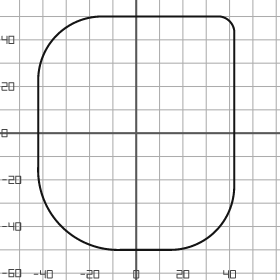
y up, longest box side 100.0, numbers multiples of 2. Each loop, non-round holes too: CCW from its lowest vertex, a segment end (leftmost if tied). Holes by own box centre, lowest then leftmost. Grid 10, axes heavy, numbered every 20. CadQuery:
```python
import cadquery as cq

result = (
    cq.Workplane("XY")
    .moveTo(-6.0, -50.0)
    .lineTo(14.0, -50.0)
    .threePointArc((34.0, -42.0), (42.0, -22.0))
    .lineTo(42.0, 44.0)
    .threePointArc((40.0, 48.0), (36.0, 50.0))
    .lineTo(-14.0, 50.0)
    .threePointArc((-34.0, 42.0), (-42.0, 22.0))
    .lineTo(-42.0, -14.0)
    .threePointArc((-32.0, -40.0), (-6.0, -50.0))
    .close()
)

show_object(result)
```